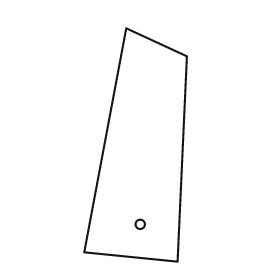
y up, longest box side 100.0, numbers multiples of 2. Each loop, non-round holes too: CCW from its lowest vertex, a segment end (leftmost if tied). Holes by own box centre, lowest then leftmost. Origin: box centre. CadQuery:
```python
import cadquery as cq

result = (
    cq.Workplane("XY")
    .moveTo(18.0, -50.0)
    .lineTo(22.0, 38.0)
    .lineTo(-4.0, 50.0)
    .lineTo(-22.0, -46.0)
    .close()
    .moveTo(2.0, -34.0)
    .circle(2.0)
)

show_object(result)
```